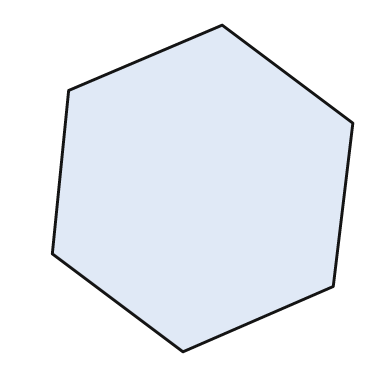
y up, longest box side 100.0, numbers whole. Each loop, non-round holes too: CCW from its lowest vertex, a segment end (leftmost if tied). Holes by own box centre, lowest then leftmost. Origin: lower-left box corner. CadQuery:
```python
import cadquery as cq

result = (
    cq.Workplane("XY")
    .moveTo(40.0, 0.0)
    .lineTo(86.0, 20.0)
    .lineTo(92.0, 70.0)
    .lineTo(52.0, 100.0)
    .lineTo(5.0, 80.0)
    .lineTo(0.0, 30.0)
    .close()
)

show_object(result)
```